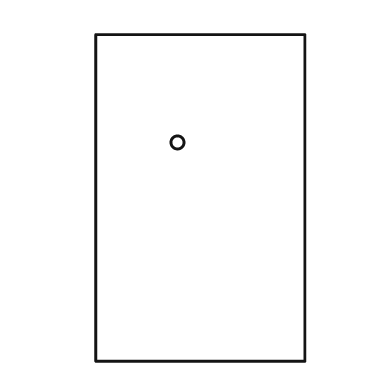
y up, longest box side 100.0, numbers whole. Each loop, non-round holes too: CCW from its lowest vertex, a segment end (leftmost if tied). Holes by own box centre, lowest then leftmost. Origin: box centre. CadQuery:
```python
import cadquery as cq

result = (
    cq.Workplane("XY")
    .moveTo(-32.0, -50.0)
    .lineTo(32.0, -50.0)
    .lineTo(32.0, 50.0)
    .lineTo(-32.0, 50.0)
    .close()
    .moveTo(-7.0, 17.0)
    .circle(2.0)
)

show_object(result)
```